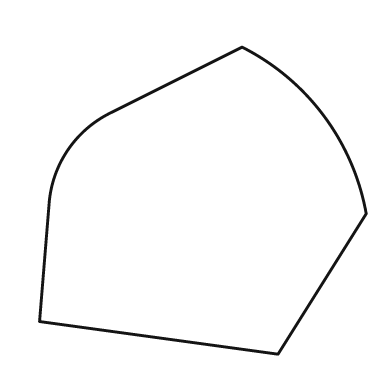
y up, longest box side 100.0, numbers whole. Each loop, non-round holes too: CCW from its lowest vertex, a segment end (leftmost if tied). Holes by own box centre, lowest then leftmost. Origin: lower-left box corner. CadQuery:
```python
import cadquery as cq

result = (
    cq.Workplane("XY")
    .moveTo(73.0, 0.0)
    .lineTo(100.0, 43.0)
    .threePointArc((87.0, 73.0), (62.0, 94.0))
    .lineTo(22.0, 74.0)
    .threePointArc((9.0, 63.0), (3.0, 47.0))
    .lineTo(0.0, 10.0)
    .close()
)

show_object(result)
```